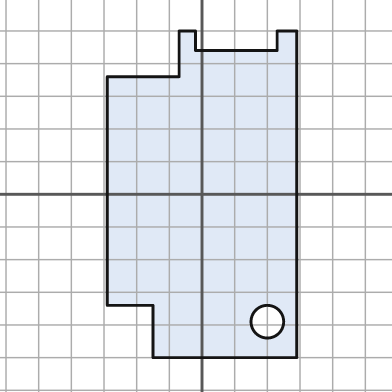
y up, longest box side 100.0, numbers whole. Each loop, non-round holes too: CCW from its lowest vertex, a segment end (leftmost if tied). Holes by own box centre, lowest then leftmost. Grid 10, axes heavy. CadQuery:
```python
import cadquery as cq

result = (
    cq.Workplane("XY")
    .moveTo(-15.0, -50.0)
    .lineTo(29.0, -50.0)
    .lineTo(29.0, 50.0)
    .lineTo(23.0, 50.0)
    .lineTo(23.0, 44.0)
    .lineTo(-2.0, 44.0)
    .lineTo(-2.0, 50.0)
    .lineTo(-7.0, 50.0)
    .lineTo(-7.0, 36.0)
    .lineTo(-29.0, 36.0)
    .lineTo(-29.0, -34.0)
    .lineTo(-15.0, -34.0)
    .close()
    .moveTo(20.0, -39.0)
    .circle(5.0)
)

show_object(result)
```